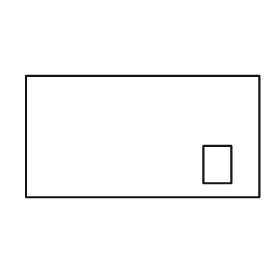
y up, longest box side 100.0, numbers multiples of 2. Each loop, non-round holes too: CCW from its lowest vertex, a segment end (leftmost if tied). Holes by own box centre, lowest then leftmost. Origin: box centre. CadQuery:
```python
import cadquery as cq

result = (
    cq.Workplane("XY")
    .moveTo(-50.0, -26.0)
    .lineTo(50.0, -26.0)
    .lineTo(50.0, 26.0)
    .lineTo(-50.0, 26.0)
    .close()
    .moveTo(26.0, -20.0)
    .lineTo(38.0, -20.0)
    .lineTo(38.0, -4.0)
    .lineTo(26.0, -4.0)
    .close()
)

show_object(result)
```